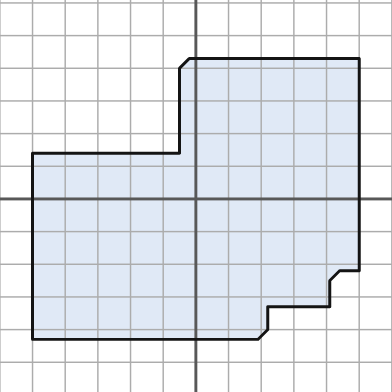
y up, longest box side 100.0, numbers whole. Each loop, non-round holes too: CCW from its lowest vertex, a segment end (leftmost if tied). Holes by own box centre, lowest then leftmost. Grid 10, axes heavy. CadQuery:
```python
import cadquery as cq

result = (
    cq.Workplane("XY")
    .moveTo(-50.0, -43.0)
    .lineTo(19.0, -43.0)
    .lineTo(22.0, -40.0)
    .lineTo(22.0, -33.0)
    .lineTo(41.0, -33.0)
    .lineTo(41.0, -25.0)
    .lineTo(44.0, -22.0)
    .lineTo(50.0, -22.0)
    .lineTo(50.0, 43.0)
    .lineTo(-2.0, 43.0)
    .lineTo(-5.0, 40.0)
    .lineTo(-5.0, 14.0)
    .lineTo(-50.0, 14.0)
    .close()
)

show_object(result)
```